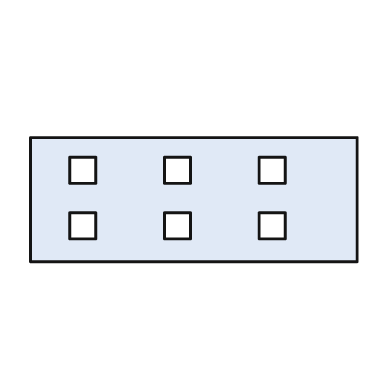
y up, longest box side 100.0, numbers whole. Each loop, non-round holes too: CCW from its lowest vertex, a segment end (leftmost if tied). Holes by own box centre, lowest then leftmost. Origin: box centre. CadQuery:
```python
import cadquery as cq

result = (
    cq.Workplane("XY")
    .moveTo(-50.0, -19.0)
    .lineTo(50.0, -19.0)
    .lineTo(50.0, 19.0)
    .lineTo(-50.0, 19.0)
    .close()
    .moveTo(-38.0, -12.0)
    .lineTo(-30.0, -12.0)
    .lineTo(-30.0, -4.0)
    .lineTo(-38.0, -4.0)
    .close()
    .moveTo(-9.0, -12.0)
    .lineTo(-1.0, -12.0)
    .lineTo(-1.0, -4.0)
    .lineTo(-9.0, -4.0)
    .close()
    .moveTo(20.0, -12.0)
    .lineTo(28.0, -12.0)
    .lineTo(28.0, -4.0)
    .lineTo(20.0, -4.0)
    .close()
    .moveTo(-38.0, 5.0)
    .lineTo(-30.0, 5.0)
    .lineTo(-30.0, 13.0)
    .lineTo(-38.0, 13.0)
    .close()
    .moveTo(-9.0, 5.0)
    .lineTo(-1.0, 5.0)
    .lineTo(-1.0, 13.0)
    .lineTo(-9.0, 13.0)
    .close()
    .moveTo(20.0, 5.0)
    .lineTo(28.0, 5.0)
    .lineTo(28.0, 13.0)
    .lineTo(20.0, 13.0)
    .close()
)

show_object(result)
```